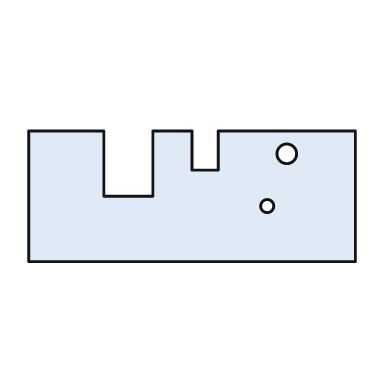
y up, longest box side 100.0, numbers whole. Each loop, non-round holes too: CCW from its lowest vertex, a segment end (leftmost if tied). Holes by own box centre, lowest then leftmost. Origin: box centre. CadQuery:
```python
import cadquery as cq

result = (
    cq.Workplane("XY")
    .moveTo(-50.0, -20.0)
    .lineTo(50.0, -20.0)
    .lineTo(50.0, 20.0)
    .lineTo(8.0, 20.0)
    .lineTo(8.0, 8.0)
    .lineTo(0.0, 8.0)
    .lineTo(0.0, 20.0)
    .lineTo(-12.0, 20.0)
    .lineTo(-12.0, 0.0)
    .lineTo(-27.0, 0.0)
    .lineTo(-27.0, 20.0)
    .lineTo(-50.0, 20.0)
    .close()
    .moveTo(23.0, -3.0)
    .circle(2.0)
    .moveTo(29.0, 13.0)
    .circle(3.0)
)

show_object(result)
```